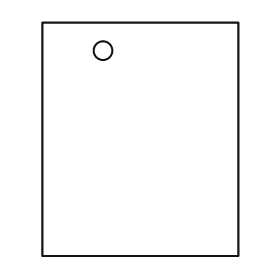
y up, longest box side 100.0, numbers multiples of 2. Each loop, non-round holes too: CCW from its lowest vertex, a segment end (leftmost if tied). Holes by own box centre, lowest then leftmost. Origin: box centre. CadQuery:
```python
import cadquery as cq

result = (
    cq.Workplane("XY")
    .moveTo(-42.0, -50.0)
    .lineTo(42.0, -50.0)
    .lineTo(42.0, 50.0)
    .lineTo(-42.0, 50.0)
    .close()
    .moveTo(-16.0, 38.0)
    .circle(4.0)
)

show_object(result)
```